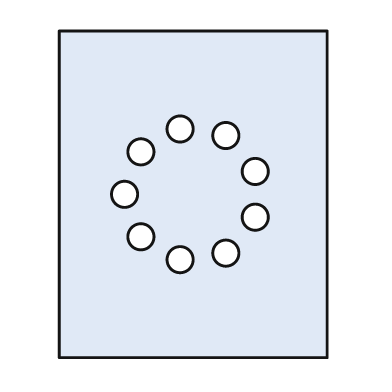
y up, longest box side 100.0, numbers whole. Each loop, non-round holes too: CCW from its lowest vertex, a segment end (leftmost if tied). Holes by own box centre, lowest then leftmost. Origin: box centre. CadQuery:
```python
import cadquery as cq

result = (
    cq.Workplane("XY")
    .moveTo(-41.0, -50.0)
    .lineTo(41.0, -50.0)
    .lineTo(41.0, 50.0)
    .lineTo(-41.0, 50.0)
    .close()
    .moveTo(-4.0, -20.0)
    .circle(4.0)
    .moveTo(10.0, -18.0)
    .circle(4.0)
    .moveTo(-16.0, -13.0)
    .circle(4.0)
    .moveTo(19.0, -7.0)
    .circle(4.0)
    .moveTo(-21.0, 0.0)
    .circle(4.0)
    .moveTo(19.0, 7.0)
    .circle(4.0)
    .moveTo(-16.0, 13.0)
    .circle(4.0)
    .moveTo(10.0, 18.0)
    .circle(4.0)
    .moveTo(-4.0, 20.0)
    .circle(4.0)
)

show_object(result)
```